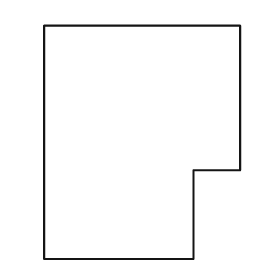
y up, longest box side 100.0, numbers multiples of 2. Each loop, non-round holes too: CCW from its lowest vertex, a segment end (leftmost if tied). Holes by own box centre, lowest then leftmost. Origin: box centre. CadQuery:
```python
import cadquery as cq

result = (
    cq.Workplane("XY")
    .moveTo(-42.0, -50.0)
    .lineTo(22.0, -50.0)
    .lineTo(22.0, -12.0)
    .lineTo(42.0, -12.0)
    .lineTo(42.0, 50.0)
    .lineTo(-42.0, 50.0)
    .close()
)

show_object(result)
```